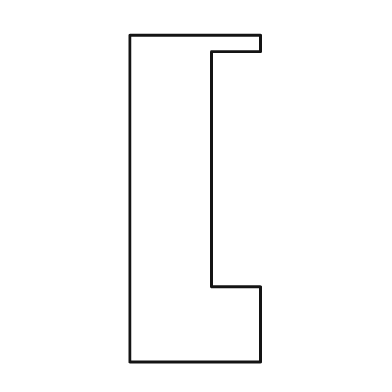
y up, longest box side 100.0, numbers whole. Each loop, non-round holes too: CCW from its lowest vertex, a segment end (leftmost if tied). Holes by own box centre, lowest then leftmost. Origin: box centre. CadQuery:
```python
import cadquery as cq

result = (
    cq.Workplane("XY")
    .moveTo(-20.0, -50.0)
    .lineTo(20.0, -50.0)
    .lineTo(20.0, -27.0)
    .lineTo(5.0, -27.0)
    .lineTo(5.0, 45.0)
    .lineTo(20.0, 45.0)
    .lineTo(20.0, 50.0)
    .lineTo(-20.0, 50.0)
    .close()
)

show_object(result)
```